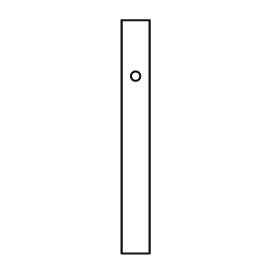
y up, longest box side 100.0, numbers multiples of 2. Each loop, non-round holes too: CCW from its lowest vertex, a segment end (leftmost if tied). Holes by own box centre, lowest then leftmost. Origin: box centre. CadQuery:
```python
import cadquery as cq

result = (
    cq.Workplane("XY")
    .moveTo(-6.0, -50.0)
    .lineTo(6.0, -50.0)
    .lineTo(6.0, 50.0)
    .lineTo(-6.0, 50.0)
    .close()
    .moveTo(0.0, 26.0)
    .circle(2.0)
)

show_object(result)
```